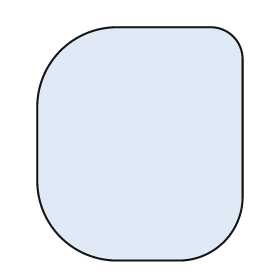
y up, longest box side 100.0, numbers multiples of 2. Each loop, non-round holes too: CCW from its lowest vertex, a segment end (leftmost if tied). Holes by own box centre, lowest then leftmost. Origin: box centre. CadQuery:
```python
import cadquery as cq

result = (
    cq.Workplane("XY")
    .moveTo(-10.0, -50.0)
    .lineTo(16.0, -50.0)
    .threePointArc((36.0, -42.0), (44.0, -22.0))
    .lineTo(44.0, 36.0)
    .threePointArc((40.0, 46.0), (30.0, 50.0))
    .lineTo(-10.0, 50.0)
    .threePointArc((-34.0, 40.0), (-44.0, 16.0))
    .lineTo(-44.0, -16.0)
    .threePointArc((-34.0, -40.0), (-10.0, -50.0))
    .close()
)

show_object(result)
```